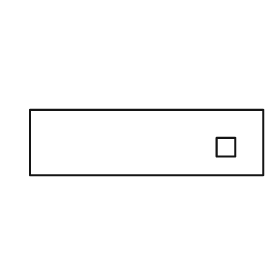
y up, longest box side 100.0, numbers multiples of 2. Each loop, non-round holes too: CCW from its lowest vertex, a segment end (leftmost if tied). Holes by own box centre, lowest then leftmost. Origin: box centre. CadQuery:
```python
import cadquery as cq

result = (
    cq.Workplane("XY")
    .moveTo(-50.0, -14.0)
    .lineTo(50.0, -14.0)
    .lineTo(50.0, 14.0)
    .lineTo(-50.0, 14.0)
    .close()
    .moveTo(30.0, -6.0)
    .lineTo(38.0, -6.0)
    .lineTo(38.0, 2.0)
    .lineTo(30.0, 2.0)
    .close()
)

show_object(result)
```